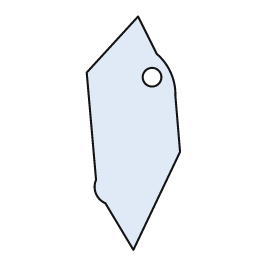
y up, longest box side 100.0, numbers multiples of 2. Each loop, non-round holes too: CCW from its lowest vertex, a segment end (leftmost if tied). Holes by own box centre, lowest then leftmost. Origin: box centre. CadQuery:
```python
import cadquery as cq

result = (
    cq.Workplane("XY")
    .moveTo(0.0, -50.0)
    .lineTo(20.0, -8.0)
    .lineTo(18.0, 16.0)
    .threePointArc((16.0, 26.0), (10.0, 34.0))
    .lineTo(2.0, 50.0)
    .lineTo(-20.0, 26.0)
    .lineTo(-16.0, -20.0)
    .threePointArc((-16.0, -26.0), (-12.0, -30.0))
    .close()
    .moveTo(8.0, 24.0)
    .circle(4.0)
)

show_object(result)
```